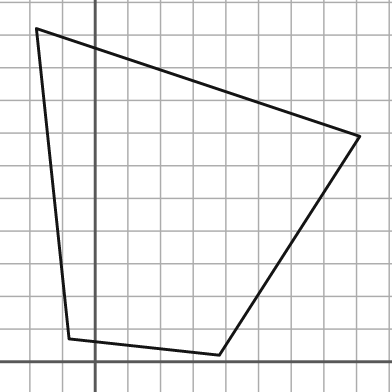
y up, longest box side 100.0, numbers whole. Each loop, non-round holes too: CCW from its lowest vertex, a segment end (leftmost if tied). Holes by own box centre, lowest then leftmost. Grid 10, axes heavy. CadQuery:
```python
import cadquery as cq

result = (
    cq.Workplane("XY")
    .moveTo(38.0, 2.0)
    .lineTo(81.0, 69.0)
    .lineTo(-18.0, 102.0)
    .lineTo(-8.0, 7.0)
    .close()
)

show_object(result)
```